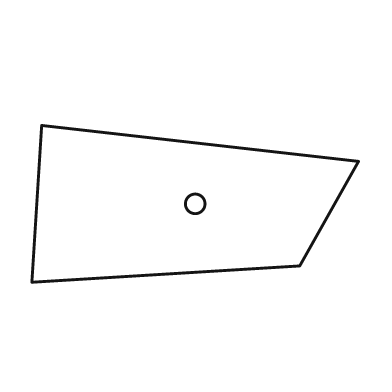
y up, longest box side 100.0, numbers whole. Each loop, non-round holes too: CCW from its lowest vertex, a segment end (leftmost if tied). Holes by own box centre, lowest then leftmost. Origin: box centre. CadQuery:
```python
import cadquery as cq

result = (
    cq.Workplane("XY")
    .moveTo(-50.0, -24.0)
    .lineTo(32.0, -19.0)
    .lineTo(50.0, 13.0)
    .lineTo(-47.0, 24.0)
    .close()
    .moveTo(0.0, 0.0)
    .circle(3.0)
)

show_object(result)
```